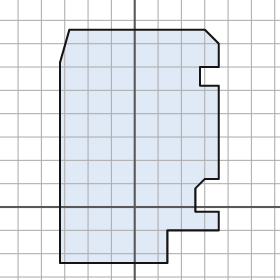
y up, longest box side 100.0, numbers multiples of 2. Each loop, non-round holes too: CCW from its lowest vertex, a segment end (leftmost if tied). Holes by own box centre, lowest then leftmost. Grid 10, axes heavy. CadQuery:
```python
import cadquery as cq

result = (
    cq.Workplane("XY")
    .moveTo(-32.0, -24.0)
    .lineTo(14.0, -24.0)
    .lineTo(14.0, -10.0)
    .lineTo(36.0, -10.0)
    .lineTo(36.0, -2.0)
    .lineTo(26.0, -2.0)
    .lineTo(26.0, 8.0)
    .lineTo(30.0, 12.0)
    .lineTo(36.0, 12.0)
    .lineTo(36.0, 52.0)
    .lineTo(28.0, 52.0)
    .lineTo(28.0, 60.0)
    .lineTo(36.0, 60.0)
    .lineTo(36.0, 70.0)
    .lineTo(30.0, 76.0)
    .lineTo(-28.0, 76.0)
    .lineTo(-32.0, 62.0)
    .close()
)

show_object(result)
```